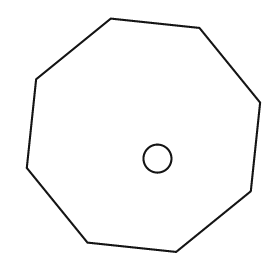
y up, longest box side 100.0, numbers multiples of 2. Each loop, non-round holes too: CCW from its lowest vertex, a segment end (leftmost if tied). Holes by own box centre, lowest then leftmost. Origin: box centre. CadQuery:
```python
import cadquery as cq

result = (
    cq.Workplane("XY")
    .moveTo(14.0, -50.0)
    .lineTo(46.0, -24.0)
    .lineTo(50.0, 14.0)
    .lineTo(24.0, 46.0)
    .lineTo(-14.0, 50.0)
    .lineTo(-46.0, 24.0)
    .lineTo(-50.0, -14.0)
    .lineTo(-24.0, -46.0)
    .close()
    .moveTo(6.0, -10.0)
    .circle(6.0)
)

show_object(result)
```